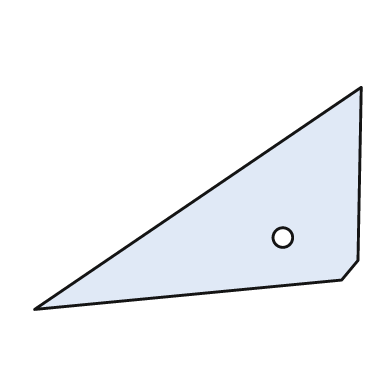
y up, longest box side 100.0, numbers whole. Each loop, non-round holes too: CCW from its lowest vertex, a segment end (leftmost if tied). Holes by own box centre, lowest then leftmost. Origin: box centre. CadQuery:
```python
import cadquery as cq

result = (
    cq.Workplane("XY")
    .moveTo(-50.0, -34.0)
    .lineTo(44.0, -25.0)
    .lineTo(49.0, -19.0)
    .lineTo(50.0, 34.0)
    .close()
    .moveTo(26.0, -12.0)
    .circle(3.0)
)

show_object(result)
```